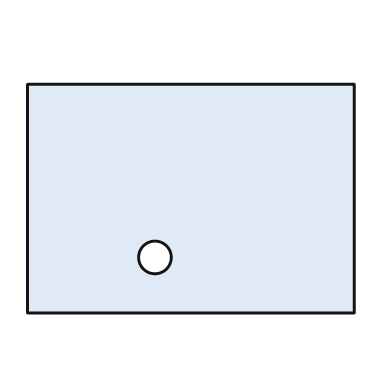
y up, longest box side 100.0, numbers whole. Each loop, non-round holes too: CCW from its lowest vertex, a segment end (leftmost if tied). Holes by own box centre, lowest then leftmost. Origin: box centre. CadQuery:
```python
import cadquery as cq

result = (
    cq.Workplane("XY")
    .moveTo(-50.0, -35.0)
    .lineTo(50.0, -35.0)
    .lineTo(50.0, 35.0)
    .lineTo(-50.0, 35.0)
    .close()
    .moveTo(-11.0, -18.0)
    .circle(5.0)
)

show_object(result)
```